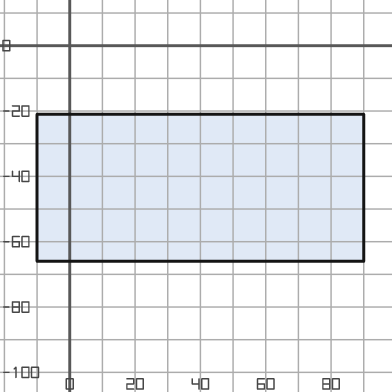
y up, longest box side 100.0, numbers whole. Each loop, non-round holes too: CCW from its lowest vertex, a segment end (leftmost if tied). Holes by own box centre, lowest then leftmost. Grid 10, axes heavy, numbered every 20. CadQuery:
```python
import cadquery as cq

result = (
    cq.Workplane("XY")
    .moveTo(-10.0, -66.0)
    .lineTo(90.0, -66.0)
    .lineTo(90.0, -21.0)
    .lineTo(-10.0, -21.0)
    .close()
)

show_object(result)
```